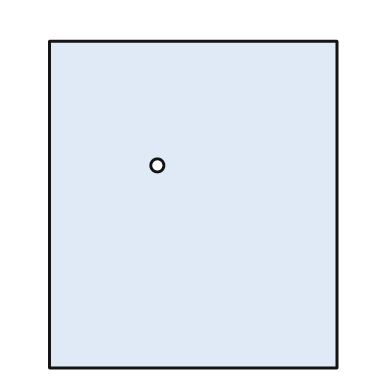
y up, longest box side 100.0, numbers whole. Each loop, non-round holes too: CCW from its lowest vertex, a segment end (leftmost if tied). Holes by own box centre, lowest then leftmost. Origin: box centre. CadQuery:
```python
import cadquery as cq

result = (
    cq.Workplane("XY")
    .moveTo(-44.0, -50.0)
    .lineTo(44.0, -50.0)
    .lineTo(44.0, 50.0)
    .lineTo(-44.0, 50.0)
    .close()
    .moveTo(-11.0, 12.0)
    .circle(2.0)
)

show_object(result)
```